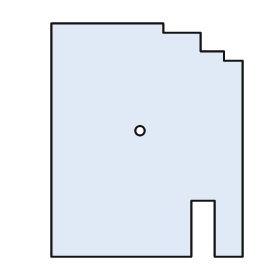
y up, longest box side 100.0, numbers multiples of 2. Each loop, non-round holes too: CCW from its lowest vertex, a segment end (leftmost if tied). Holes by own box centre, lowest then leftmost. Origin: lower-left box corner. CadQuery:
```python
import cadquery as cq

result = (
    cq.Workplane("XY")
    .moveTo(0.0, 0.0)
    .lineTo(60.0, 0.0)
    .lineTo(60.0, 24.0)
    .lineTo(70.0, 24.0)
    .lineTo(70.0, 0.0)
    .lineTo(82.0, 0.0)
    .lineTo(82.0, 84.0)
    .lineTo(74.0, 84.0)
    .lineTo(74.0, 88.0)
    .lineTo(64.0, 88.0)
    .lineTo(64.0, 96.0)
    .lineTo(48.0, 96.0)
    .lineTo(48.0, 100.0)
    .lineTo(0.0, 100.0)
    .close()
    .moveTo(38.0, 54.0)
    .circle(2.0)
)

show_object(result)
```